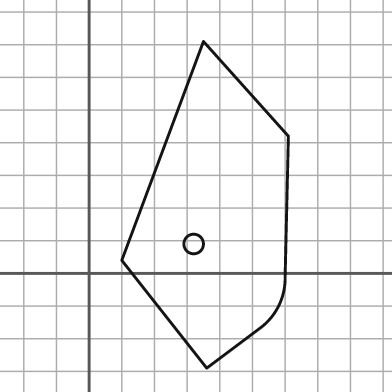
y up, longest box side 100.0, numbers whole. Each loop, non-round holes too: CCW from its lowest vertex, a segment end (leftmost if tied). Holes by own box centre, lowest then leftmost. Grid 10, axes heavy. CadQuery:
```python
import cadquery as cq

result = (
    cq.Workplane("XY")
    .moveTo(36.0, -29.0)
    .lineTo(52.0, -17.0)
    .threePointArc((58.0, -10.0), (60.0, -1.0))
    .lineTo(61.0, 42.0)
    .lineTo(35.0, 71.0)
    .lineTo(10.0, 4.0)
    .close()
    .moveTo(32.0, 9.0)
    .circle(3.0)
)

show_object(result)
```